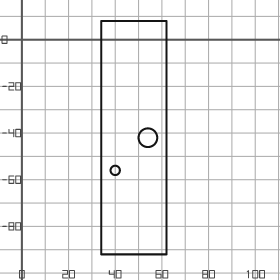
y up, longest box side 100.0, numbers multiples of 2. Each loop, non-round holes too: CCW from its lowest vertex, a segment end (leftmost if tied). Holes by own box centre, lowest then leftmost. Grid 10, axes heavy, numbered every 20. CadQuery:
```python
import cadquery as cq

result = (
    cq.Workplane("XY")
    .moveTo(34.0, -92.0)
    .lineTo(62.0, -92.0)
    .lineTo(62.0, 8.0)
    .lineTo(34.0, 8.0)
    .close()
    .moveTo(40.0, -56.0)
    .circle(2.0)
    .moveTo(54.0, -42.0)
    .circle(4.0)
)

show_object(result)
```